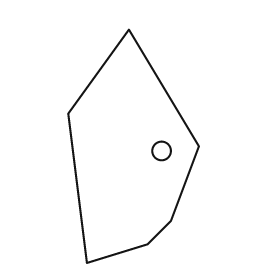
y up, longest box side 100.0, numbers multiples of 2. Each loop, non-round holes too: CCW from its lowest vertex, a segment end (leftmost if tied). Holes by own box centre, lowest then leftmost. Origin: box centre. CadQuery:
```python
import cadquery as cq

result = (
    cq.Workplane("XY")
    .moveTo(-20.0, -50.0)
    .lineTo(6.0, -42.0)
    .lineTo(16.0, -32.0)
    .lineTo(28.0, 0.0)
    .lineTo(-2.0, 50.0)
    .lineTo(-28.0, 14.0)
    .close()
    .moveTo(12.0, -2.0)
    .circle(4.0)
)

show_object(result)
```